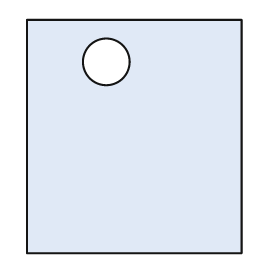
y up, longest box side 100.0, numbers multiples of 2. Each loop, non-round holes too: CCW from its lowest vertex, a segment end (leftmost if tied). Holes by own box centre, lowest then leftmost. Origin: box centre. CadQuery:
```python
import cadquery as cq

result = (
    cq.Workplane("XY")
    .moveTo(-46.0, -50.0)
    .lineTo(46.0, -50.0)
    .lineTo(46.0, 50.0)
    .lineTo(-46.0, 50.0)
    .close()
    .moveTo(-12.0, 32.0)
    .circle(10.0)
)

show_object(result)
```